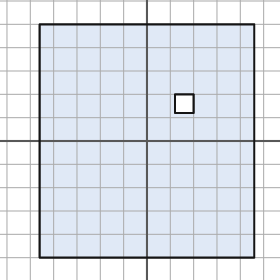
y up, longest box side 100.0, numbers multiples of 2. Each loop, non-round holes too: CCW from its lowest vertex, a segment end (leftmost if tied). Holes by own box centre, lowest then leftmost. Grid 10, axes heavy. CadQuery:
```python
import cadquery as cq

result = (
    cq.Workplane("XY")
    .moveTo(-46.0, -50.0)
    .lineTo(46.0, -50.0)
    .lineTo(46.0, 50.0)
    .lineTo(-46.0, 50.0)
    .close()
    .moveTo(12.0, 12.0)
    .lineTo(20.0, 12.0)
    .lineTo(20.0, 20.0)
    .lineTo(12.0, 20.0)
    .close()
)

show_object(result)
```